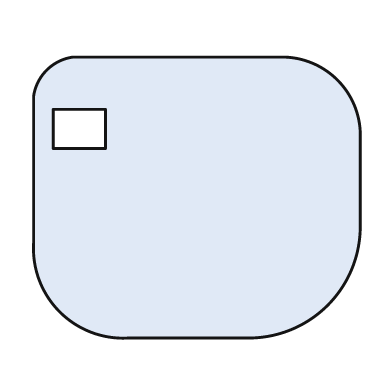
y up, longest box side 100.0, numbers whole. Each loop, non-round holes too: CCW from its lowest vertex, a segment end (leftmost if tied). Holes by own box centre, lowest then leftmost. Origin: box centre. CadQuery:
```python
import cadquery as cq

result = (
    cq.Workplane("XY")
    .moveTo(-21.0, -43.0)
    .lineTo(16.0, -43.0)
    .threePointArc((40.0, -33.0), (50.0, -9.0))
    .lineTo(50.0, 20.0)
    .threePointArc((43.0, 36.0), (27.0, 43.0))
    .lineTo(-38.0, 43.0)
    .threePointArc((-46.0, 39.0), (-50.0, 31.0))
    .lineTo(-50.0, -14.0)
    .threePointArc((-42.0, -35.0), (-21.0, -43.0))
    .close()
    .moveTo(-44.0, 15.0)
    .lineTo(-28.0, 15.0)
    .lineTo(-28.0, 27.0)
    .lineTo(-44.0, 27.0)
    .close()
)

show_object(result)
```